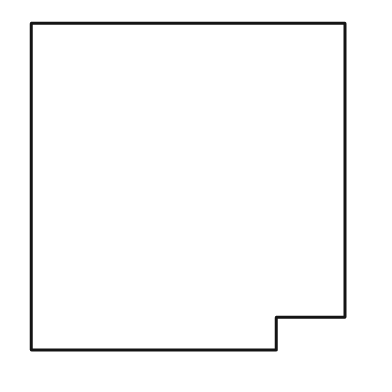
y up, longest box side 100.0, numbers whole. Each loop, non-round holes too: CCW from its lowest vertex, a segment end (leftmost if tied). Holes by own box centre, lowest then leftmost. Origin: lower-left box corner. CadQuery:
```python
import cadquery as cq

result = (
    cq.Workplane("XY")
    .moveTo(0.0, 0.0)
    .lineTo(75.0, 0.0)
    .lineTo(75.0, 10.0)
    .lineTo(96.0, 10.0)
    .lineTo(96.0, 100.0)
    .lineTo(0.0, 100.0)
    .close()
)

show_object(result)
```